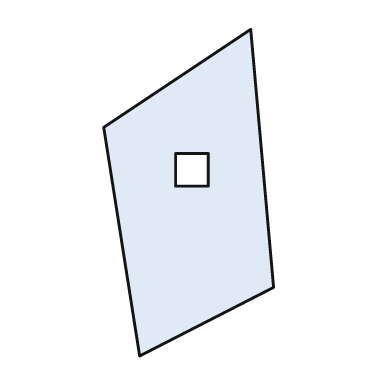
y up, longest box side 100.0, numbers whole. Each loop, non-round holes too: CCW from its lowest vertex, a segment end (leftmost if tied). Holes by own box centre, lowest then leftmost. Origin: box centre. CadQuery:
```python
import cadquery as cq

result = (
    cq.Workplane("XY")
    .moveTo(-15.0, -50.0)
    .lineTo(26.0, -29.0)
    .lineTo(19.0, 50.0)
    .lineTo(-26.0, 20.0)
    .close()
    .moveTo(-4.0, 2.0)
    .lineTo(6.0, 2.0)
    .lineTo(6.0, 12.0)
    .lineTo(-4.0, 12.0)
    .close()
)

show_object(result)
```